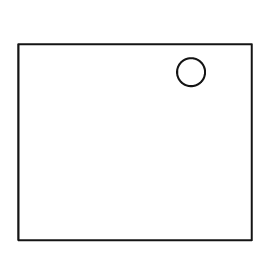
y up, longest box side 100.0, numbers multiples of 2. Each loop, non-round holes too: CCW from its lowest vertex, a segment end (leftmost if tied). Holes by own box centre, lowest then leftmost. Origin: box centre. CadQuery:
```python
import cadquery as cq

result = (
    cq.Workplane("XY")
    .moveTo(-50.0, -42.0)
    .lineTo(50.0, -42.0)
    .lineTo(50.0, 42.0)
    .lineTo(-50.0, 42.0)
    .close()
    .moveTo(24.0, 30.0)
    .circle(6.0)
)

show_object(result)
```